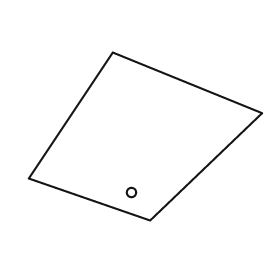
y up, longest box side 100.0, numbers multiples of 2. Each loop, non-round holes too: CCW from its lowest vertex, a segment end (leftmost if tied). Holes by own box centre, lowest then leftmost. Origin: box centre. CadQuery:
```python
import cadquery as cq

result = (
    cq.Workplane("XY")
    .moveTo(2.0, -36.0)
    .lineTo(50.0, 10.0)
    .lineTo(-14.0, 36.0)
    .lineTo(-50.0, -18.0)
    .close()
    .moveTo(-6.0, -24.0)
    .circle(2.0)
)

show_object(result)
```